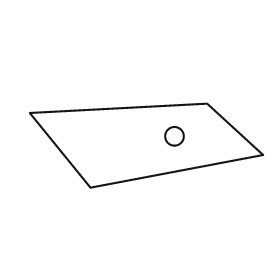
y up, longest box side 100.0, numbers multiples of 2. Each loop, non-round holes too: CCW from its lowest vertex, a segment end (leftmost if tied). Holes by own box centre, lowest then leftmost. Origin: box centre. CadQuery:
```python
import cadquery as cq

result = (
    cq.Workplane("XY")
    .moveTo(-24.0, -18.0)
    .lineTo(50.0, -4.0)
    .lineTo(26.0, 18.0)
    .lineTo(-50.0, 14.0)
    .close()
    .moveTo(12.0, 4.0)
    .circle(4.0)
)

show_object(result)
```